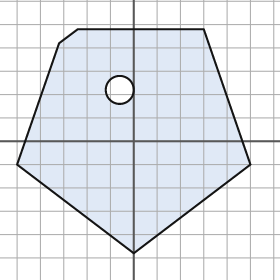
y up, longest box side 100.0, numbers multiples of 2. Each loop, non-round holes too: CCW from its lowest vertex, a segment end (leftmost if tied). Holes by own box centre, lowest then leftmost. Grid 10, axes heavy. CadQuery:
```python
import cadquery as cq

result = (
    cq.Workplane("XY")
    .moveTo(0.0, -48.0)
    .lineTo(50.0, -10.0)
    .lineTo(30.0, 48.0)
    .lineTo(-24.0, 48.0)
    .lineTo(-32.0, 42.0)
    .lineTo(-50.0, -10.0)
    .close()
    .moveTo(-6.0, 22.0)
    .circle(6.0)
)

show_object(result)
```